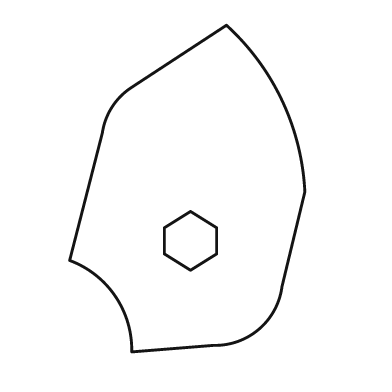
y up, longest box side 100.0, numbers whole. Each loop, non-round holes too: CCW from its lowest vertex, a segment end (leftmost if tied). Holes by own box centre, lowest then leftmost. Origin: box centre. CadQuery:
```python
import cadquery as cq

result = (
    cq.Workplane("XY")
    .moveTo(-17.0, -50.0)
    .lineTo(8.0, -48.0)
    .threePointArc((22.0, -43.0), (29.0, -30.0))
    .lineTo(36.0, -1.0)
    .threePointArc((29.0, 27.0), (12.0, 50.0))
    .lineTo(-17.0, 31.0)
    .threePointArc((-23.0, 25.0), (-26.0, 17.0))
    .lineTo(-36.0, -22.0)
    .threePointArc((-22.0, -33.0), (-17.0, -50.0))
    .close()
    .moveTo(1.0, -25.0)
    .lineTo(9.0, -20.0)
    .lineTo(9.0, -12.0)
    .lineTo(1.0, -7.0)
    .lineTo(-7.0, -12.0)
    .lineTo(-7.0, -20.0)
    .close()
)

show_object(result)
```